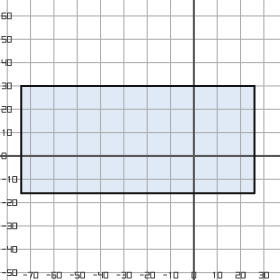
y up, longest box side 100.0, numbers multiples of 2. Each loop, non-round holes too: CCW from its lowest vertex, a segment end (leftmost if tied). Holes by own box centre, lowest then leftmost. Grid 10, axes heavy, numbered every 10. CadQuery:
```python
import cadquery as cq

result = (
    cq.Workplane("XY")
    .moveTo(-74.0, -16.0)
    .lineTo(26.0, -16.0)
    .lineTo(26.0, 30.0)
    .lineTo(-74.0, 30.0)
    .close()
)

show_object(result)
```